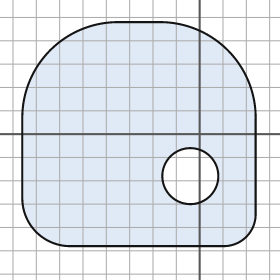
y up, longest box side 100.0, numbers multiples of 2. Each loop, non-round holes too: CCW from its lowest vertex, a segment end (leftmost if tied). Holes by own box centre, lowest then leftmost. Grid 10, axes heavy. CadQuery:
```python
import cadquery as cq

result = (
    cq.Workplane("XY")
    .moveTo(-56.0, -48.0)
    .lineTo(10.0, -48.0)
    .threePointArc((20.0, -44.0), (24.0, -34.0))
    .lineTo(24.0, 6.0)
    .threePointArc((12.0, 36.0), (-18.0, 48.0))
    .lineTo(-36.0, 48.0)
    .threePointArc((-64.0, 36.0), (-76.0, 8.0))
    .lineTo(-76.0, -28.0)
    .threePointArc((-70.0, -42.0), (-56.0, -48.0))
    .close()
    .moveTo(-4.0, -18.0)
    .circle(12.0)
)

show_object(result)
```